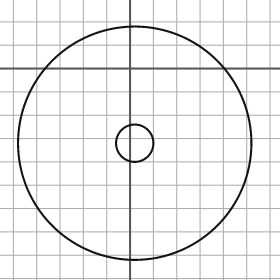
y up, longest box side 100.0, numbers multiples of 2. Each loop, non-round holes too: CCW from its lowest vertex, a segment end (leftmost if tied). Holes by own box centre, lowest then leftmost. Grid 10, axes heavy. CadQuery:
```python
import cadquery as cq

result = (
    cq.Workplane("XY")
    .moveTo(2.0, -32.0)
    .circle(50.0)
    .moveTo(2.0, -32.0)
    .circle(8.0)
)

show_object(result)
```